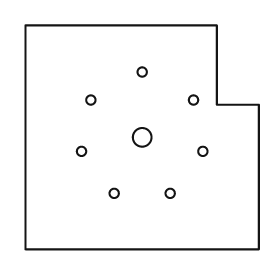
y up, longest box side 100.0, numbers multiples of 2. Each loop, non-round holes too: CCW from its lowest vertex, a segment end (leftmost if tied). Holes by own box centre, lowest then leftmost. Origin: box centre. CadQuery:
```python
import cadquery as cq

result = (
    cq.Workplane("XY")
    .moveTo(-50.0, -48.0)
    .lineTo(50.0, -48.0)
    .lineTo(50.0, 14.0)
    .lineTo(32.0, 14.0)
    .lineTo(32.0, 48.0)
    .lineTo(-50.0, 48.0)
    .close()
    .moveTo(-12.0, -24.0)
    .circle(2.0)
    .moveTo(12.0, -24.0)
    .circle(2.0)
    .moveTo(-26.0, -6.0)
    .circle(2.0)
    .moveTo(26.0, -6.0)
    .circle(2.0)
    .moveTo(0.0, 0.0)
    .circle(4.0)
    .moveTo(-22.0, 16.0)
    .circle(2.0)
    .moveTo(22.0, 16.0)
    .circle(2.0)
    .moveTo(0.0, 28.0)
    .circle(2.0)
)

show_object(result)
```